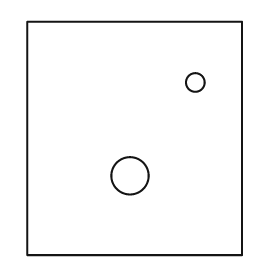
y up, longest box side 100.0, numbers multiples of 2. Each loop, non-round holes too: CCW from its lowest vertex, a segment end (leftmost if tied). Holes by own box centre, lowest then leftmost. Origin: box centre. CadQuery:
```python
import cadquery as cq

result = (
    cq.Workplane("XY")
    .moveTo(-46.0, -50.0)
    .lineTo(46.0, -50.0)
    .lineTo(46.0, 50.0)
    .lineTo(-46.0, 50.0)
    .close()
    .moveTo(-2.0, -16.0)
    .circle(8.0)
    .moveTo(26.0, 24.0)
    .circle(4.0)
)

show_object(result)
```